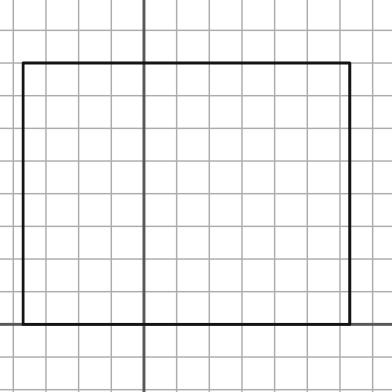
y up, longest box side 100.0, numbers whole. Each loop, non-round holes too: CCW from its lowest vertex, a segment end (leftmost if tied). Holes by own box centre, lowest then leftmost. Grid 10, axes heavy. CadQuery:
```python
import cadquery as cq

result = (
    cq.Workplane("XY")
    .moveTo(-37.0, 0.0)
    .lineTo(63.0, 0.0)
    .lineTo(63.0, 80.0)
    .lineTo(-37.0, 80.0)
    .close()
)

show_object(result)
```